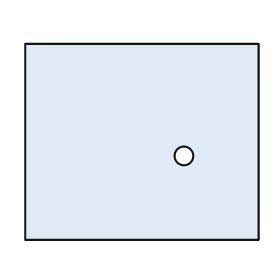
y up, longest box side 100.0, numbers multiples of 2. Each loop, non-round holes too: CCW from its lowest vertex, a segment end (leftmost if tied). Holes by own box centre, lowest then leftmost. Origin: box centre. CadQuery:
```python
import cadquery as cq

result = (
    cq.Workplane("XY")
    .moveTo(-50.0, -42.0)
    .lineTo(50.0, -42.0)
    .lineTo(50.0, 42.0)
    .lineTo(-50.0, 42.0)
    .close()
    .moveTo(18.0, -6.0)
    .circle(4.0)
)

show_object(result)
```